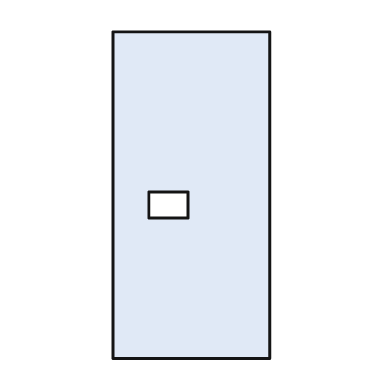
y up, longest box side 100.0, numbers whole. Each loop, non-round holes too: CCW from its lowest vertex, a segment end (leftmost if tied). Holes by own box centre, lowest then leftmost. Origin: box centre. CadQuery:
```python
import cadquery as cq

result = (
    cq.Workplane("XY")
    .moveTo(-24.0, -50.0)
    .lineTo(24.0, -50.0)
    .lineTo(24.0, 50.0)
    .lineTo(-24.0, 50.0)
    .close()
    .moveTo(-13.0, -7.0)
    .lineTo(-1.0, -7.0)
    .lineTo(-1.0, 1.0)
    .lineTo(-13.0, 1.0)
    .close()
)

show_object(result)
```